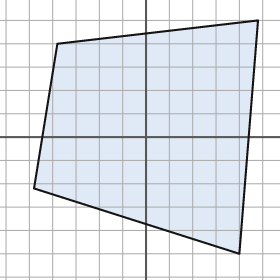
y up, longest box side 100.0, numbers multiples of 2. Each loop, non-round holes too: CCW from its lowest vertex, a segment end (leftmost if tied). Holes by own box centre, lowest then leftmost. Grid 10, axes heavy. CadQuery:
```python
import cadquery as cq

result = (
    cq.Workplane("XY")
    .moveTo(40.0, -50.0)
    .lineTo(48.0, 50.0)
    .lineTo(-38.0, 40.0)
    .lineTo(-48.0, -22.0)
    .close()
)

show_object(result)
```